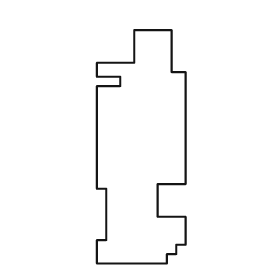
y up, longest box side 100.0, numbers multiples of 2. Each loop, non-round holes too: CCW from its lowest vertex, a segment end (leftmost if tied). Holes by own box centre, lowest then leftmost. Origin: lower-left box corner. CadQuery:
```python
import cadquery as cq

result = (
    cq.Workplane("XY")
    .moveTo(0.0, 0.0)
    .lineTo(30.0, 0.0)
    .lineTo(30.0, 4.0)
    .lineTo(34.0, 4.0)
    .lineTo(34.0, 8.0)
    .lineTo(38.0, 8.0)
    .lineTo(38.0, 20.0)
    .lineTo(26.0, 20.0)
    .lineTo(26.0, 34.0)
    .lineTo(38.0, 34.0)
    .lineTo(38.0, 82.0)
    .lineTo(32.0, 82.0)
    .lineTo(32.0, 100.0)
    .lineTo(16.0, 100.0)
    .lineTo(16.0, 86.0)
    .lineTo(0.0, 86.0)
    .lineTo(0.0, 80.0)
    .lineTo(10.0, 80.0)
    .lineTo(10.0, 76.0)
    .lineTo(0.0, 76.0)
    .lineTo(0.0, 32.0)
    .lineTo(4.0, 32.0)
    .lineTo(4.0, 10.0)
    .lineTo(0.0, 10.0)
    .close()
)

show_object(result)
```